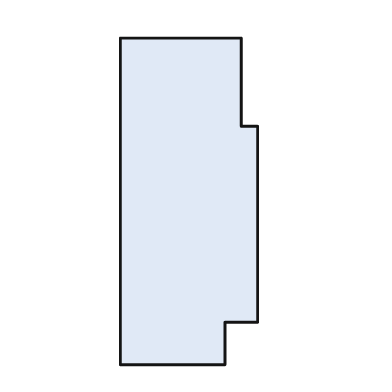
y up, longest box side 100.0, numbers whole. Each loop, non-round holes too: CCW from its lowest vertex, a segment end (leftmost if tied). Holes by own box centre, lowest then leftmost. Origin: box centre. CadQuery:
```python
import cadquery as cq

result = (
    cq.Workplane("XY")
    .moveTo(-21.0, -50.0)
    .lineTo(11.0, -50.0)
    .lineTo(11.0, -37.0)
    .lineTo(21.0, -37.0)
    .lineTo(21.0, 23.0)
    .lineTo(16.0, 23.0)
    .lineTo(16.0, 50.0)
    .lineTo(-21.0, 50.0)
    .close()
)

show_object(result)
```